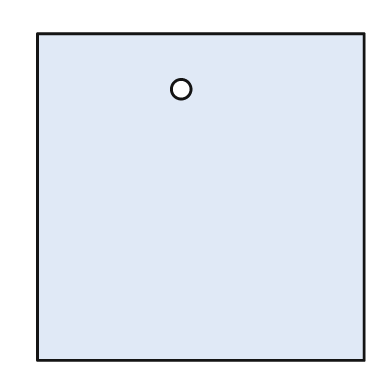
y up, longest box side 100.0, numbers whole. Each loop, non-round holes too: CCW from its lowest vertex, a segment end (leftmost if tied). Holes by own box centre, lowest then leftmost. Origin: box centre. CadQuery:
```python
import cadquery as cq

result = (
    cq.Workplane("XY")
    .moveTo(-50.0, -50.0)
    .lineTo(50.0, -50.0)
    .lineTo(50.0, 50.0)
    .lineTo(-50.0, 50.0)
    .close()
    .moveTo(-6.0, 33.0)
    .circle(3.0)
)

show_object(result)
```